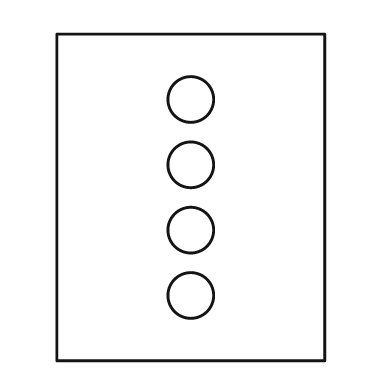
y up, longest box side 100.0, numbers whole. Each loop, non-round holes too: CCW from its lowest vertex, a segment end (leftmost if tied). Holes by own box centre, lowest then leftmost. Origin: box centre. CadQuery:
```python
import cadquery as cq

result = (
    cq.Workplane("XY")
    .moveTo(-41.0, -50.0)
    .lineTo(41.0, -50.0)
    .lineTo(41.0, 50.0)
    .lineTo(-41.0, 50.0)
    .close()
    .moveTo(0.0, -30.0)
    .circle(7.0)
    .moveTo(0.0, -10.0)
    .circle(7.0)
    .moveTo(0.0, 10.0)
    .circle(7.0)
    .moveTo(0.0, 30.0)
    .circle(7.0)
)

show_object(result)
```